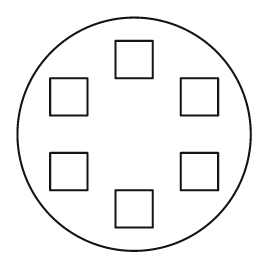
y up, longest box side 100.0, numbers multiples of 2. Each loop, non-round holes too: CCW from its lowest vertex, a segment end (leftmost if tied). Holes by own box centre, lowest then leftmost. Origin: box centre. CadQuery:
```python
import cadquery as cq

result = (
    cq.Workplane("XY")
    .moveTo(0.0, 0.0)
    .circle(50.0)
    .moveTo(-8.0, -40.0)
    .lineTo(8.0, -40.0)
    .lineTo(8.0, -24.0)
    .lineTo(-8.0, -24.0)
    .close()
    .moveTo(-36.0, -24.0)
    .lineTo(-20.0, -24.0)
    .lineTo(-20.0, -8.0)
    .lineTo(-36.0, -8.0)
    .close()
    .moveTo(20.0, -24.0)
    .lineTo(36.0, -24.0)
    .lineTo(36.0, -8.0)
    .lineTo(20.0, -8.0)
    .close()
    .moveTo(-36.0, 8.0)
    .lineTo(-20.0, 8.0)
    .lineTo(-20.0, 24.0)
    .lineTo(-36.0, 24.0)
    .close()
    .moveTo(20.0, 8.0)
    .lineTo(36.0, 8.0)
    .lineTo(36.0, 24.0)
    .lineTo(20.0, 24.0)
    .close()
    .moveTo(-8.0, 24.0)
    .lineTo(8.0, 24.0)
    .lineTo(8.0, 40.0)
    .lineTo(-8.0, 40.0)
    .close()
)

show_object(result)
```